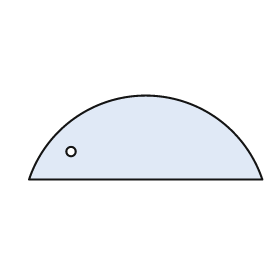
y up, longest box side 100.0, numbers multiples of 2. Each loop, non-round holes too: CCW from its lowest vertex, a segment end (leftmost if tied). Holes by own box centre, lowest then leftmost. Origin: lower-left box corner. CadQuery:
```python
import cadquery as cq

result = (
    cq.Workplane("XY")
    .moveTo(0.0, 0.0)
    .lineTo(100.0, 0.0)
    .threePointArc((50.0, 36.0), (0.0, 0.0))
    .close()
    .moveTo(18.0, 12.0)
    .circle(2.0)
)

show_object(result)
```